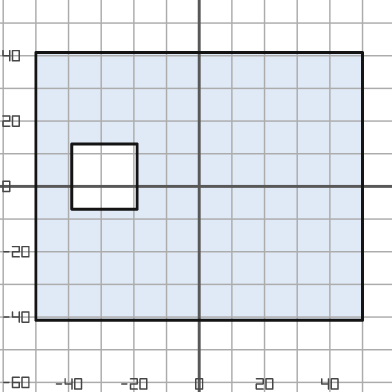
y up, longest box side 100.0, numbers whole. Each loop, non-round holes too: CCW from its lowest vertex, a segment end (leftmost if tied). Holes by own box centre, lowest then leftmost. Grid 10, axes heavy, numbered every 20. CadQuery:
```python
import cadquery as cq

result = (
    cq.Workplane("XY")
    .moveTo(-50.0, -41.0)
    .lineTo(50.0, -41.0)
    .lineTo(50.0, 41.0)
    .lineTo(-50.0, 41.0)
    .close()
    .moveTo(-39.0, -7.0)
    .lineTo(-19.0, -7.0)
    .lineTo(-19.0, 13.0)
    .lineTo(-39.0, 13.0)
    .close()
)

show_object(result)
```